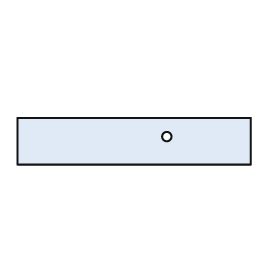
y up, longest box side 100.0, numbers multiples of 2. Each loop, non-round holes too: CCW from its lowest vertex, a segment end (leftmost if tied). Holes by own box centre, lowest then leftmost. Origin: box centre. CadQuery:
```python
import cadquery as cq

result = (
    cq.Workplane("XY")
    .moveTo(-50.0, -10.0)
    .lineTo(50.0, -10.0)
    .lineTo(50.0, 10.0)
    .lineTo(-50.0, 10.0)
    .close()
    .moveTo(14.0, 2.0)
    .circle(2.0)
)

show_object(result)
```